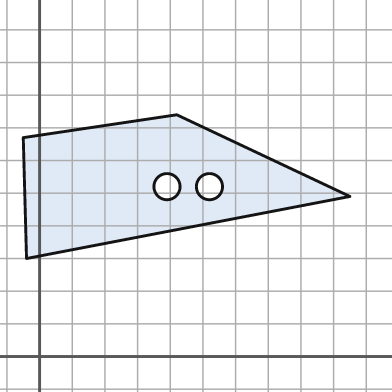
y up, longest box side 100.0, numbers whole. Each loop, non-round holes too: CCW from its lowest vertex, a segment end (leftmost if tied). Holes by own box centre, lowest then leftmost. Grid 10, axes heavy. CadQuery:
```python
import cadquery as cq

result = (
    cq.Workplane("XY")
    .moveTo(-4.0, 30.0)
    .lineTo(95.0, 49.0)
    .lineTo(42.0, 74.0)
    .lineTo(-5.0, 67.0)
    .close()
    .moveTo(39.0, 52.0)
    .circle(4.0)
    .moveTo(52.0, 52.0)
    .circle(4.0)
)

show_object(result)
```